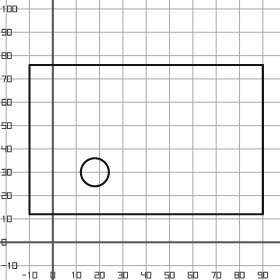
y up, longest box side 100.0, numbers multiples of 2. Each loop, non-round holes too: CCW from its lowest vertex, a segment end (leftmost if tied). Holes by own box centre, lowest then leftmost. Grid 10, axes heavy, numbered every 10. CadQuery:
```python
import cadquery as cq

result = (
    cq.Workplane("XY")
    .moveTo(-10.0, 12.0)
    .lineTo(90.0, 12.0)
    .lineTo(90.0, 76.0)
    .lineTo(-10.0, 76.0)
    .close()
    .moveTo(18.0, 30.0)
    .circle(6.0)
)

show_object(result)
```